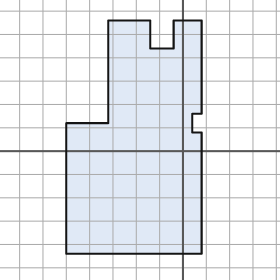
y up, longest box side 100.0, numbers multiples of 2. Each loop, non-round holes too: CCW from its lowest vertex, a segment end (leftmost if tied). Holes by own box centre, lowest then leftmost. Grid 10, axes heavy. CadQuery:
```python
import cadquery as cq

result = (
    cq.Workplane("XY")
    .moveTo(-50.0, -44.0)
    .lineTo(8.0, -44.0)
    .lineTo(8.0, 8.0)
    .lineTo(4.0, 8.0)
    .lineTo(4.0, 16.0)
    .lineTo(8.0, 16.0)
    .lineTo(8.0, 56.0)
    .lineTo(-4.0, 56.0)
    .lineTo(-4.0, 44.0)
    .lineTo(-14.0, 44.0)
    .lineTo(-14.0, 56.0)
    .lineTo(-32.0, 56.0)
    .lineTo(-32.0, 12.0)
    .lineTo(-50.0, 12.0)
    .close()
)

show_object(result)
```